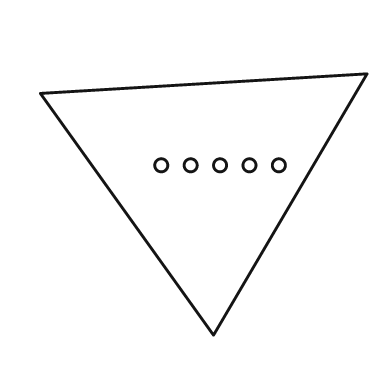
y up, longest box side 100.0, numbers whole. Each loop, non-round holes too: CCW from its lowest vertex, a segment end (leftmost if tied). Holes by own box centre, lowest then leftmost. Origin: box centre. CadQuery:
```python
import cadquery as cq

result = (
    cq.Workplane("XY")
    .moveTo(3.0, -40.0)
    .lineTo(50.0, 40.0)
    .lineTo(-50.0, 34.0)
    .close()
    .moveTo(-13.0, 12.0)
    .circle(2.0)
    .moveTo(-4.0, 12.0)
    .circle(2.0)
    .moveTo(5.0, 12.0)
    .circle(2.0)
    .moveTo(14.0, 12.0)
    .circle(2.0)
    .moveTo(23.0, 12.0)
    .circle(2.0)
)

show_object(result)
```